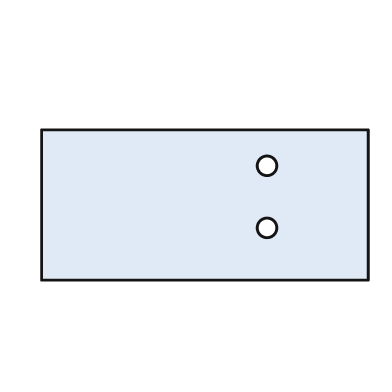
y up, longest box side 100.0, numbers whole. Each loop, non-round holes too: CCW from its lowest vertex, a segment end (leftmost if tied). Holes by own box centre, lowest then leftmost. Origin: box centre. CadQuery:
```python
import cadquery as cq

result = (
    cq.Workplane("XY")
    .moveTo(-50.0, -23.0)
    .lineTo(50.0, -23.0)
    .lineTo(50.0, 23.0)
    .lineTo(-50.0, 23.0)
    .close()
    .moveTo(19.0, -7.0)
    .circle(3.0)
    .moveTo(19.0, 12.0)
    .circle(3.0)
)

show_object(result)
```